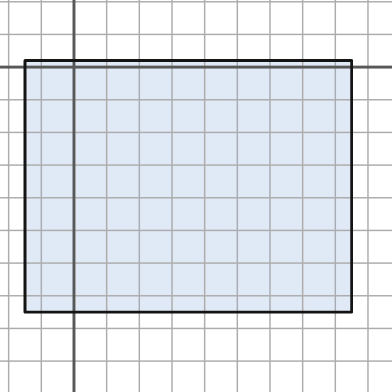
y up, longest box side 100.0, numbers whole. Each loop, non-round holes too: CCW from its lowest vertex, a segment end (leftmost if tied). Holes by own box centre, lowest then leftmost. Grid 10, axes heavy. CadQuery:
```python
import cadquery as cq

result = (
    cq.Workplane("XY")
    .moveTo(-15.0, -75.0)
    .lineTo(85.0, -75.0)
    .lineTo(85.0, 2.0)
    .lineTo(-15.0, 2.0)
    .close()
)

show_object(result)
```